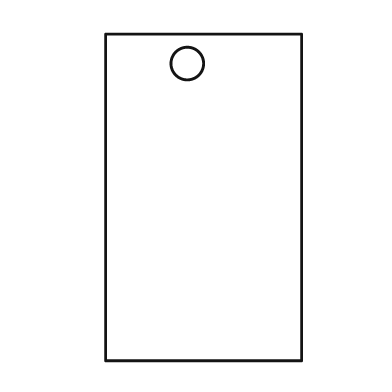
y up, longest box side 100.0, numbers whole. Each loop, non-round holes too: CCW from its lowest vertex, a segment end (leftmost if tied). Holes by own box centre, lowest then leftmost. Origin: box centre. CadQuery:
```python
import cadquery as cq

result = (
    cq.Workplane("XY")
    .moveTo(-30.0, -50.0)
    .lineTo(30.0, -50.0)
    .lineTo(30.0, 50.0)
    .lineTo(-30.0, 50.0)
    .close()
    .moveTo(-5.0, 41.0)
    .circle(5.0)
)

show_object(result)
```